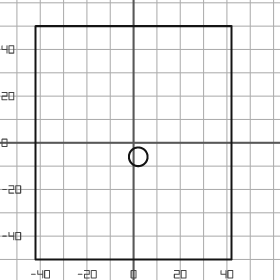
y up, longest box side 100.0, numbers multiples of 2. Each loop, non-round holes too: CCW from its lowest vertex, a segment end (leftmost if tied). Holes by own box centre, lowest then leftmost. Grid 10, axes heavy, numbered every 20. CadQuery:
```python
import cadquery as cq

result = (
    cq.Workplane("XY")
    .moveTo(-42.0, -50.0)
    .lineTo(42.0, -50.0)
    .lineTo(42.0, 50.0)
    .lineTo(-42.0, 50.0)
    .close()
    .moveTo(2.0, -6.0)
    .circle(4.0)
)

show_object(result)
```